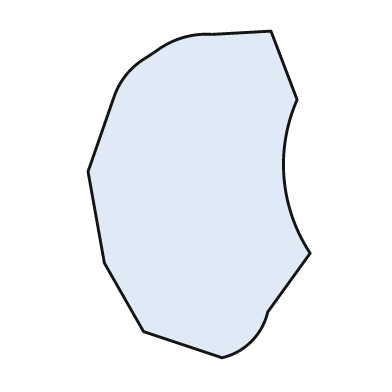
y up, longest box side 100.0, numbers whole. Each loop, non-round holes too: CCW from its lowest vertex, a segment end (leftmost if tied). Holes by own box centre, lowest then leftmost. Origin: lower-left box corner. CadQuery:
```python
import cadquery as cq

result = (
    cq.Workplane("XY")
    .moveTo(41.0, 0.0)
    .threePointArc((50.0, 5.0), (55.0, 14.0))
    .lineTo(68.0, 32.0)
    .threePointArc((60.0, 55.0), (64.0, 79.0))
    .lineTo(56.0, 100.0)
    .lineTo(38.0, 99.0)
    .threePointArc((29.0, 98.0), (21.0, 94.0))
    .lineTo(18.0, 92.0)
    .threePointArc((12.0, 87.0), (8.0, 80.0))
    .lineTo(0.0, 57.0)
    .lineTo(5.0, 29.0)
    .lineTo(17.0, 8.0)
    .close()
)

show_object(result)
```